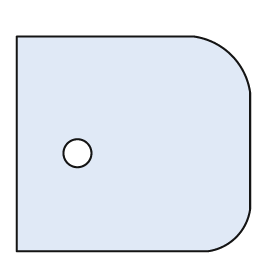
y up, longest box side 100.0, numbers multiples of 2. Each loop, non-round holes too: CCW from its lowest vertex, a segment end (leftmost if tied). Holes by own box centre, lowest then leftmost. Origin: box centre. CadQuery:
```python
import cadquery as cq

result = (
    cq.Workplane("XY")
    .moveTo(-50.0, -46.0)
    .lineTo(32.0, -46.0)
    .threePointArc((44.0, -40.0), (50.0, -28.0))
    .lineTo(50.0, 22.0)
    .threePointArc((42.0, 38.0), (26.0, 46.0))
    .lineTo(-50.0, 46.0)
    .close()
    .moveTo(-24.0, -4.0)
    .circle(6.0)
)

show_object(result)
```